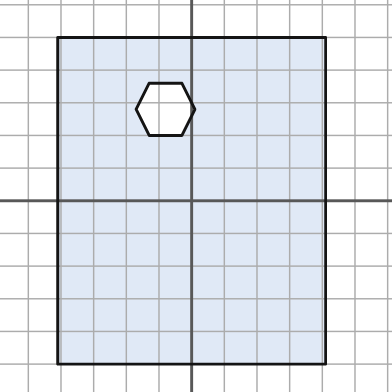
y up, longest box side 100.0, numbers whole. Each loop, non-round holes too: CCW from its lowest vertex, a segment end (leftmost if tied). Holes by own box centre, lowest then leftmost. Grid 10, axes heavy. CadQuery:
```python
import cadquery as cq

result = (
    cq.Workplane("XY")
    .moveTo(-41.0, -50.0)
    .lineTo(41.0, -50.0)
    .lineTo(41.0, 50.0)
    .lineTo(-41.0, 50.0)
    .close()
    .moveTo(-13.0, 20.0)
    .lineTo(-3.0, 20.0)
    .lineTo(1.0, 28.0)
    .lineTo(-3.0, 36.0)
    .lineTo(-13.0, 36.0)
    .lineTo(-17.0, 28.0)
    .close()
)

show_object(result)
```